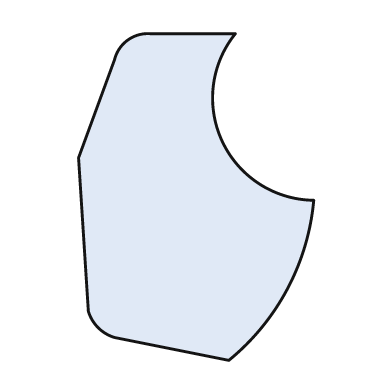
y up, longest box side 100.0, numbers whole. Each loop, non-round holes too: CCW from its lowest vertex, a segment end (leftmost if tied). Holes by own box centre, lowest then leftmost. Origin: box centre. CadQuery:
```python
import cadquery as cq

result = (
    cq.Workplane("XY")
    .moveTo(10.0, -50.0)
    .threePointArc((28.0, -28.0), (36.0, -1.0))
    .threePointArc((8.0, 17.0), (12.0, 50.0))
    .lineTo(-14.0, 50.0)
    .threePointArc((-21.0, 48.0), (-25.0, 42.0))
    .lineTo(-36.0, 12.0)
    .lineTo(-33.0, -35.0)
    .threePointArc((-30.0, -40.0), (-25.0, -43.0))
    .close()
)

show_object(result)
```